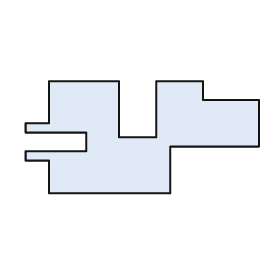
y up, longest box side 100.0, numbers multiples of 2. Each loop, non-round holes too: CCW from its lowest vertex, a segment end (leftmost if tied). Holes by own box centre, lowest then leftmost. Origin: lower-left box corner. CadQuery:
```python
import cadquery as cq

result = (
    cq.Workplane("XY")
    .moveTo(10.0, 0.0)
    .lineTo(62.0, 0.0)
    .lineTo(62.0, 20.0)
    .lineTo(100.0, 20.0)
    .lineTo(100.0, 40.0)
    .lineTo(76.0, 40.0)
    .lineTo(76.0, 48.0)
    .lineTo(56.0, 48.0)
    .lineTo(56.0, 24.0)
    .lineTo(40.0, 24.0)
    .lineTo(40.0, 48.0)
    .lineTo(10.0, 48.0)
    .lineTo(10.0, 30.0)
    .lineTo(0.0, 30.0)
    .lineTo(0.0, 26.0)
    .lineTo(26.0, 26.0)
    .lineTo(26.0, 18.0)
    .lineTo(0.0, 18.0)
    .lineTo(0.0, 14.0)
    .lineTo(10.0, 14.0)
    .close()
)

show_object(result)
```